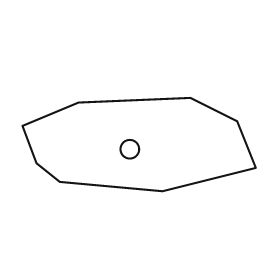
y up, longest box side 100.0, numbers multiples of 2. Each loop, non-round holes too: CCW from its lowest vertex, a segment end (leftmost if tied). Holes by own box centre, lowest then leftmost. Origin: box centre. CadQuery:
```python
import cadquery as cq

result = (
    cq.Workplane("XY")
    .moveTo(10.0, -20.0)
    .lineTo(50.0, -10.0)
    .lineTo(42.0, 10.0)
    .lineTo(22.0, 20.0)
    .lineTo(-26.0, 18.0)
    .lineTo(-50.0, 8.0)
    .lineTo(-44.0, -8.0)
    .lineTo(-34.0, -16.0)
    .close()
    .moveTo(-4.0, -2.0)
    .circle(4.0)
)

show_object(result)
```